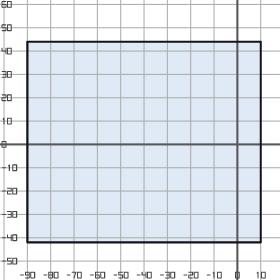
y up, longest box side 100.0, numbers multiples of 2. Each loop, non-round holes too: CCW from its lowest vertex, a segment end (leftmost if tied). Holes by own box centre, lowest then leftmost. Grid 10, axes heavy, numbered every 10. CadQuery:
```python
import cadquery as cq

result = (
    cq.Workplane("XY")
    .moveTo(-90.0, -42.0)
    .lineTo(10.0, -42.0)
    .lineTo(10.0, 44.0)
    .lineTo(-90.0, 44.0)
    .close()
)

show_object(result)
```